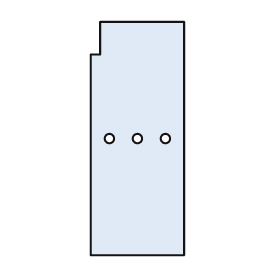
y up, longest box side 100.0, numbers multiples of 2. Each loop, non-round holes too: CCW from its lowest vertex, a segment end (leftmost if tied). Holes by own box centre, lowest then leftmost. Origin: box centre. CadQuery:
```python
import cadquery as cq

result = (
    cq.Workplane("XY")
    .moveTo(-20.0, -50.0)
    .lineTo(20.0, -50.0)
    .lineTo(20.0, 50.0)
    .lineTo(-16.0, 50.0)
    .lineTo(-16.0, 36.0)
    .lineTo(-20.0, 36.0)
    .close()
    .moveTo(-12.0, 0.0)
    .circle(2.0)
    .moveTo(0.0, 0.0)
    .circle(2.0)
    .moveTo(12.0, 0.0)
    .circle(2.0)
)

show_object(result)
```